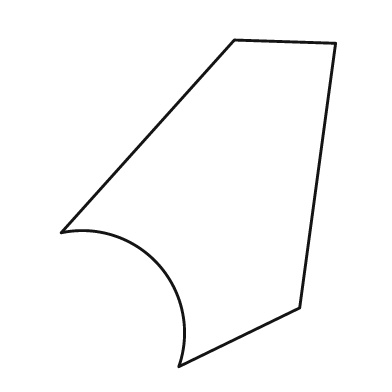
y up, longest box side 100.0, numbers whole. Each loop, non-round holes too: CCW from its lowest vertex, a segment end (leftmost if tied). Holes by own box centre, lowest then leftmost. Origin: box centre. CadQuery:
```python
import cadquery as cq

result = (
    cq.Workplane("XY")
    .moveTo(-6.0, -50.0)
    .lineTo(31.0, -32.0)
    .lineTo(42.0, 49.0)
    .lineTo(11.0, 50.0)
    .lineTo(-42.0, -9.0)
    .threePointArc((-12.0, -19.0), (-6.0, -50.0))
    .close()
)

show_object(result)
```